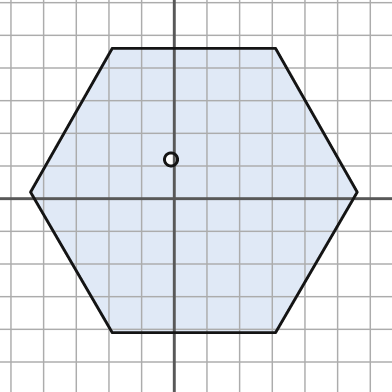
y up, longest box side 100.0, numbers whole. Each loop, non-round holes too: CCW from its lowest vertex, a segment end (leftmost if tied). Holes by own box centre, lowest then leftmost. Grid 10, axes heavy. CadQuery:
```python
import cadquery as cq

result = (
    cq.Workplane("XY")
    .moveTo(-19.0, -41.0)
    .lineTo(31.0, -41.0)
    .lineTo(56.0, 2.0)
    .lineTo(31.0, 46.0)
    .lineTo(-19.0, 46.0)
    .lineTo(-44.0, 2.0)
    .close()
    .moveTo(-1.0, 12.0)
    .circle(2.0)
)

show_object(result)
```